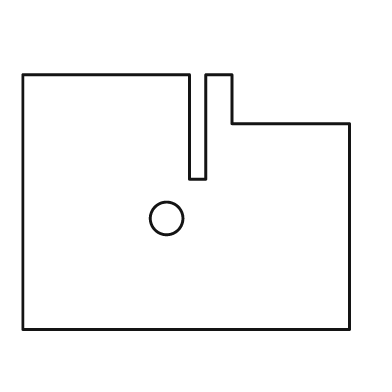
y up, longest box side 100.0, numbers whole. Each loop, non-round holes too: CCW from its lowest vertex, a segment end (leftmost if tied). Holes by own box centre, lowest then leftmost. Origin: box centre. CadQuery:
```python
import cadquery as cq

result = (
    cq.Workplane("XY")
    .moveTo(-50.0, -39.0)
    .lineTo(50.0, -39.0)
    .lineTo(50.0, 24.0)
    .lineTo(14.0, 24.0)
    .lineTo(14.0, 39.0)
    .lineTo(6.0, 39.0)
    .lineTo(6.0, 7.0)
    .lineTo(1.0, 7.0)
    .lineTo(1.0, 39.0)
    .lineTo(-50.0, 39.0)
    .close()
    .moveTo(-6.0, -5.0)
    .circle(5.0)
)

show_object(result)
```